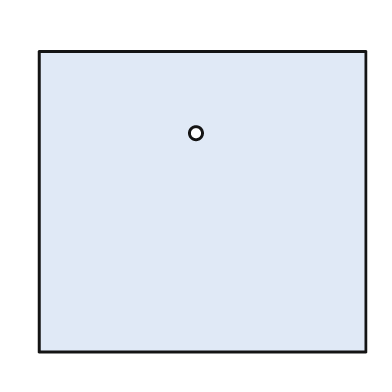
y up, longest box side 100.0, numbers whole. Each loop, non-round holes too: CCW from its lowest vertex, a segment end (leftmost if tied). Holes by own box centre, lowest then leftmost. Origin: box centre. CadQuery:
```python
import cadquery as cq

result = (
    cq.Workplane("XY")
    .moveTo(-50.0, -46.0)
    .lineTo(50.0, -46.0)
    .lineTo(50.0, 46.0)
    .lineTo(-50.0, 46.0)
    .close()
    .moveTo(-2.0, 21.0)
    .circle(2.0)
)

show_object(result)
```